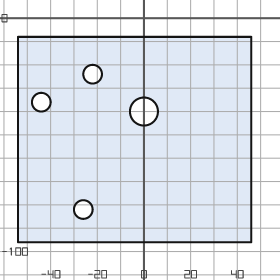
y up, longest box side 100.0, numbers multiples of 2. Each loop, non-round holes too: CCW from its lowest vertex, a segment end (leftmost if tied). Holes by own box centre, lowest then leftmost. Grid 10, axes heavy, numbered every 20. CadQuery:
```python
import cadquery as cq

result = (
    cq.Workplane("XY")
    .moveTo(-54.0, -96.0)
    .lineTo(46.0, -96.0)
    .lineTo(46.0, -8.0)
    .lineTo(-54.0, -8.0)
    .close()
    .moveTo(-26.0, -82.0)
    .circle(4.0)
    .moveTo(0.0, -40.0)
    .circle(6.0)
    .moveTo(-44.0, -36.0)
    .circle(4.0)
    .moveTo(-22.0, -24.0)
    .circle(4.0)
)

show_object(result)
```